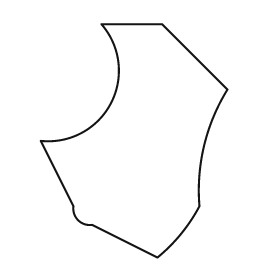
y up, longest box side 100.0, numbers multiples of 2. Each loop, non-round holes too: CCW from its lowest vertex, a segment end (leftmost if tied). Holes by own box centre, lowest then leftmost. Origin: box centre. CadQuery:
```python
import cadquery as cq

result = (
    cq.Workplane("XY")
    .moveTo(10.0, -50.0)
    .threePointArc((20.0, -40.0), (28.0, -28.0))
    .threePointArc((30.0, -2.0), (40.0, 22.0))
    .lineTo(12.0, 50.0)
    .lineTo(-14.0, 50.0)
    .threePointArc((-10.0, 16.0), (-40.0, 0.0))
    .lineTo(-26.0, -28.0)
    .threePointArc((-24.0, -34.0), (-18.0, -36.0))
    .close()
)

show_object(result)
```